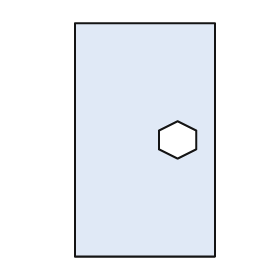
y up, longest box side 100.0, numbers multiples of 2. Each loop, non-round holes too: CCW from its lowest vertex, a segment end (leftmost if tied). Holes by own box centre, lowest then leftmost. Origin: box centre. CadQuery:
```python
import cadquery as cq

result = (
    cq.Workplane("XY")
    .moveTo(-30.0, -50.0)
    .lineTo(30.0, -50.0)
    .lineTo(30.0, 50.0)
    .lineTo(-30.0, 50.0)
    .close()
    .moveTo(14.0, -8.0)
    .lineTo(22.0, -4.0)
    .lineTo(22.0, 4.0)
    .lineTo(14.0, 8.0)
    .lineTo(6.0, 4.0)
    .lineTo(6.0, -4.0)
    .close()
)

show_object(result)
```